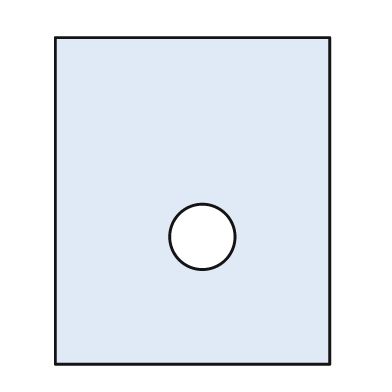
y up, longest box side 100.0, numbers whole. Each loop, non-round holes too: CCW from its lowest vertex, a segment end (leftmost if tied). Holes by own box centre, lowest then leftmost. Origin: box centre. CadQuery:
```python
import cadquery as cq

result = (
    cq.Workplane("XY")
    .moveTo(-42.0, -50.0)
    .lineTo(42.0, -50.0)
    .lineTo(42.0, 50.0)
    .lineTo(-42.0, 50.0)
    .close()
    .moveTo(3.0, -11.0)
    .circle(10.0)
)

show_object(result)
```